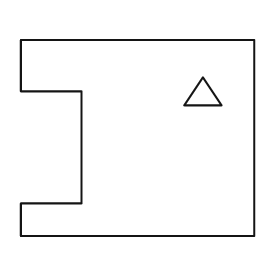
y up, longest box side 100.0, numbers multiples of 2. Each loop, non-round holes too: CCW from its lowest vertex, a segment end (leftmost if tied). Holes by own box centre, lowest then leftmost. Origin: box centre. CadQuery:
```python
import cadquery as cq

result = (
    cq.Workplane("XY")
    .moveTo(-50.0, -42.0)
    .lineTo(50.0, -42.0)
    .lineTo(50.0, 42.0)
    .lineTo(-50.0, 42.0)
    .lineTo(-50.0, 20.0)
    .lineTo(-24.0, 20.0)
    .lineTo(-24.0, -28.0)
    .lineTo(-50.0, -28.0)
    .close()
    .moveTo(20.0, 14.0)
    .lineTo(36.0, 14.0)
    .lineTo(28.0, 26.0)
    .close()
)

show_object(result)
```